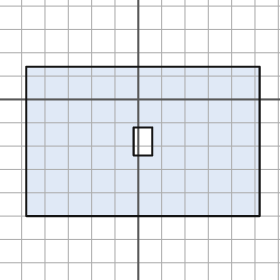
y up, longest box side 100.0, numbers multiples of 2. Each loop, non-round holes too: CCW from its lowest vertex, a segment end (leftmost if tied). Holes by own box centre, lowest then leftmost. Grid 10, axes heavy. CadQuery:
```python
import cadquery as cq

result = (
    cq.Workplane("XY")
    .moveTo(-48.0, -50.0)
    .lineTo(52.0, -50.0)
    .lineTo(52.0, 14.0)
    .lineTo(-48.0, 14.0)
    .close()
    .moveTo(-2.0, -24.0)
    .lineTo(6.0, -24.0)
    .lineTo(6.0, -12.0)
    .lineTo(-2.0, -12.0)
    .close()
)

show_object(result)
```